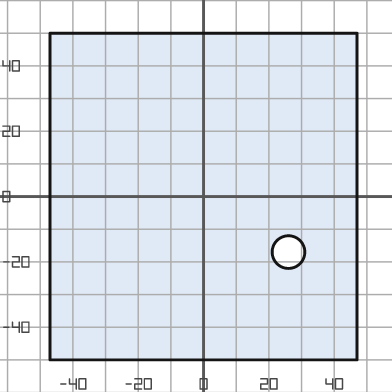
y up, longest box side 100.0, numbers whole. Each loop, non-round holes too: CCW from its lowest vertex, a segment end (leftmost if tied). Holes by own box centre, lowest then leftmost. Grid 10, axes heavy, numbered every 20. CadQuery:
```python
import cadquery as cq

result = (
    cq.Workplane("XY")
    .moveTo(-47.0, -50.0)
    .lineTo(47.0, -50.0)
    .lineTo(47.0, 50.0)
    .lineTo(-47.0, 50.0)
    .close()
    .moveTo(26.0, -17.0)
    .circle(5.0)
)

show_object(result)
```